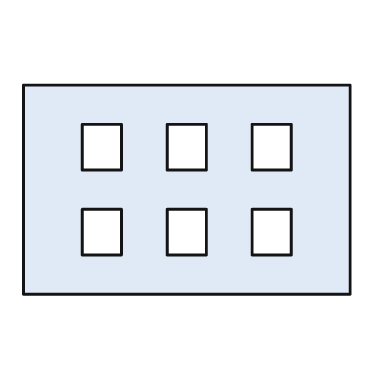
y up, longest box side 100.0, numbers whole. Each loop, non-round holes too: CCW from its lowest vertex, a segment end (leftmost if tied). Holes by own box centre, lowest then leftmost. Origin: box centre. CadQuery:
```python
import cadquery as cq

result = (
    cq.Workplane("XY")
    .moveTo(-50.0, -32.0)
    .lineTo(50.0, -32.0)
    .lineTo(50.0, 32.0)
    .lineTo(-50.0, 32.0)
    .close()
    .moveTo(-32.0, -20.0)
    .lineTo(-20.0, -20.0)
    .lineTo(-20.0, -6.0)
    .lineTo(-32.0, -6.0)
    .close()
    .moveTo(-6.0, -20.0)
    .lineTo(6.0, -20.0)
    .lineTo(6.0, -6.0)
    .lineTo(-6.0, -6.0)
    .close()
    .moveTo(20.0, -20.0)
    .lineTo(32.0, -20.0)
    .lineTo(32.0, -6.0)
    .lineTo(20.0, -6.0)
    .close()
    .moveTo(-32.0, 6.0)
    .lineTo(-20.0, 6.0)
    .lineTo(-20.0, 20.0)
    .lineTo(-32.0, 20.0)
    .close()
    .moveTo(-6.0, 6.0)
    .lineTo(6.0, 6.0)
    .lineTo(6.0, 20.0)
    .lineTo(-6.0, 20.0)
    .close()
    .moveTo(20.0, 6.0)
    .lineTo(32.0, 6.0)
    .lineTo(32.0, 20.0)
    .lineTo(20.0, 20.0)
    .close()
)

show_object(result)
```